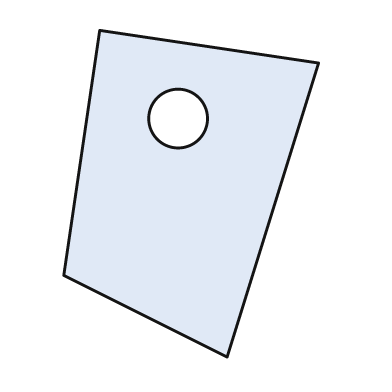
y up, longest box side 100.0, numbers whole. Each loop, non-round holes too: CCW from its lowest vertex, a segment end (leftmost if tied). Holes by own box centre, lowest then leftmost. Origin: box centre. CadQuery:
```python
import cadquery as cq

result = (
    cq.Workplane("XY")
    .moveTo(11.0, -50.0)
    .lineTo(39.0, 40.0)
    .lineTo(-28.0, 50.0)
    .lineTo(-39.0, -25.0)
    .close()
    .moveTo(-4.0, 23.0)
    .circle(9.0)
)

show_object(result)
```